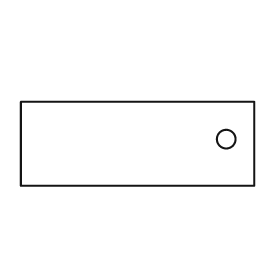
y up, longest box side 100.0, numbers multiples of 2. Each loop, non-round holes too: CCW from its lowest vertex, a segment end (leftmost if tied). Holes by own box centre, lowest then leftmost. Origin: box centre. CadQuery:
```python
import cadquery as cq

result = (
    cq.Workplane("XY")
    .moveTo(-50.0, -18.0)
    .lineTo(50.0, -18.0)
    .lineTo(50.0, 18.0)
    .lineTo(-50.0, 18.0)
    .close()
    .moveTo(38.0, 2.0)
    .circle(4.0)
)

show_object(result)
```